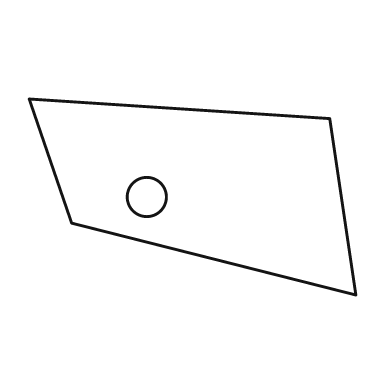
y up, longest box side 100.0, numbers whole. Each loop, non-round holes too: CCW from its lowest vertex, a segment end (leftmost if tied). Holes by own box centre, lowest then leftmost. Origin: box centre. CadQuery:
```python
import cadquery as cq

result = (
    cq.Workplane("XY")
    .moveTo(50.0, -30.0)
    .lineTo(42.0, 24.0)
    .lineTo(-50.0, 30.0)
    .lineTo(-37.0, -8.0)
    .close()
    .moveTo(-14.0, 0.0)
    .circle(6.0)
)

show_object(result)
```